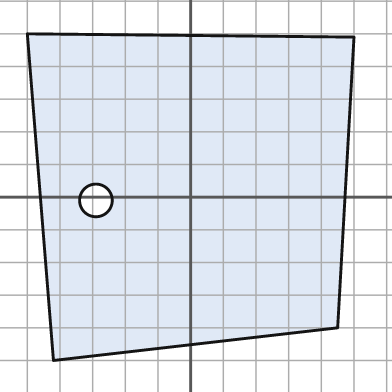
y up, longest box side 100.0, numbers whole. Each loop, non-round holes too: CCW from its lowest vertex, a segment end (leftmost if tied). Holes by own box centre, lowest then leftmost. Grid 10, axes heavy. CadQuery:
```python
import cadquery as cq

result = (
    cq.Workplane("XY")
    .moveTo(-42.0, -50.0)
    .lineTo(45.0, -40.0)
    .lineTo(50.0, 49.0)
    .lineTo(-50.0, 50.0)
    .close()
    .moveTo(-29.0, -1.0)
    .circle(5.0)
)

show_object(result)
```